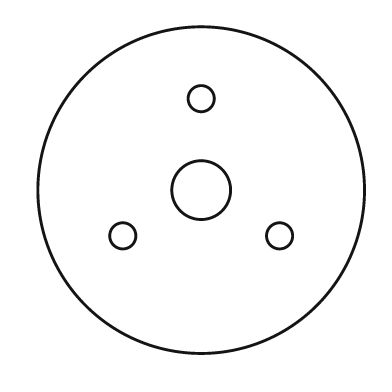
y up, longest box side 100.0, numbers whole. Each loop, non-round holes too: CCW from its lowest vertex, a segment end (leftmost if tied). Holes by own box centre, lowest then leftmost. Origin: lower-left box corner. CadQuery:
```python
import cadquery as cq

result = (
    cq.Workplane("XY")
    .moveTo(50.0, 50.0)
    .circle(50.0)
    .moveTo(26.0, 36.0)
    .circle(4.0)
    .moveTo(74.0, 36.0)
    .circle(4.0)
    .moveTo(50.0, 50.0)
    .circle(9.0)
    .moveTo(50.0, 78.0)
    .circle(4.0)
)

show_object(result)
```